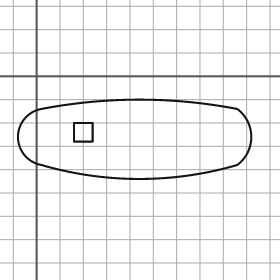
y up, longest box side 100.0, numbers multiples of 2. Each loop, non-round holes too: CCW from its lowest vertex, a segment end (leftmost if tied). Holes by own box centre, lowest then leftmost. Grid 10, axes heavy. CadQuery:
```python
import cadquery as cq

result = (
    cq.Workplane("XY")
    .moveTo(2.0, -38.0)
    .threePointArc((44.0, -44.0), (86.0, -38.0))
    .threePointArc((92.0, -26.0), (86.0, -14.0))
    .threePointArc((44.0, -10.0), (2.0, -14.0))
    .threePointArc((-8.0, -26.0), (2.0, -38.0))
    .close()
    .moveTo(16.0, -28.0)
    .lineTo(24.0, -28.0)
    .lineTo(24.0, -20.0)
    .lineTo(16.0, -20.0)
    .close()
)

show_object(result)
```